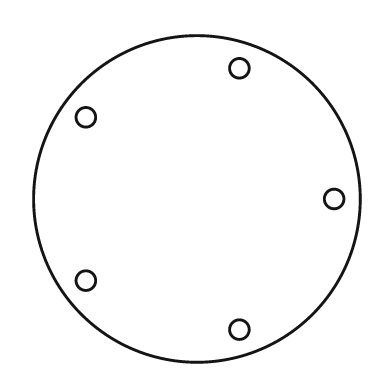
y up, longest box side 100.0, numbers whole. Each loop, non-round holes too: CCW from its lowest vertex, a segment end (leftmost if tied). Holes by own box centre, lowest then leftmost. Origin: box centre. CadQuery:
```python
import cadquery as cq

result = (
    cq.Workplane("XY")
    .moveTo(0.0, 0.0)
    .circle(50.0)
    .moveTo(13.0, -40.0)
    .circle(3.0)
    .moveTo(-34.0, -25.0)
    .circle(3.0)
    .moveTo(42.0, 0.0)
    .circle(3.0)
    .moveTo(-34.0, 25.0)
    .circle(3.0)
    .moveTo(13.0, 40.0)
    .circle(3.0)
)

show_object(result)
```